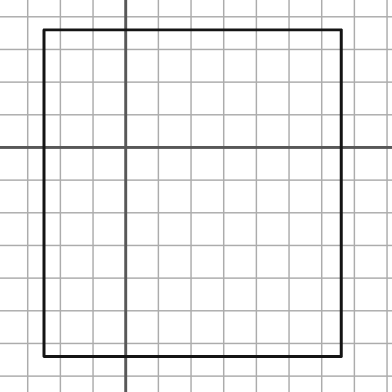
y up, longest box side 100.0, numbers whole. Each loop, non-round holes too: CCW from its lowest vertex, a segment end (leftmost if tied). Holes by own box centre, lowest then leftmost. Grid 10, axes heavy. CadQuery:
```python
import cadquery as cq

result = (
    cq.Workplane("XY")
    .moveTo(-25.0, -64.0)
    .lineTo(66.0, -64.0)
    .lineTo(66.0, 36.0)
    .lineTo(-25.0, 36.0)
    .close()
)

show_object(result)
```